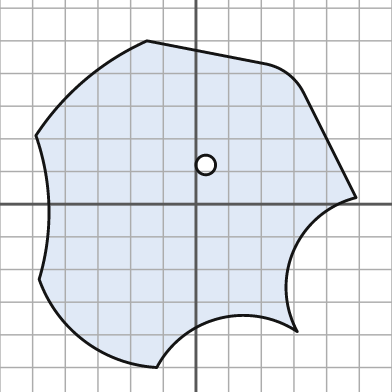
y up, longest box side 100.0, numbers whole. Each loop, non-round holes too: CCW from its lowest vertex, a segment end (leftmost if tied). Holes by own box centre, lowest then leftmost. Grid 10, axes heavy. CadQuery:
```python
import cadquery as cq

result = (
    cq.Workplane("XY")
    .moveTo(-12.0, -50.0)
    .threePointArc((7.0, -35.0), (31.0, -39.0))
    .threePointArc((30.0, -14.0), (49.0, 2.0))
    .lineTo(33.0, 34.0)
    .threePointArc((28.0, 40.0), (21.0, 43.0))
    .lineTo(-15.0, 50.0)
    .threePointArc((-34.0, 38.0), (-49.0, 21.0))
    .threePointArc((-45.0, -1.0), (-48.0, -23.0))
    .threePointArc((-34.0, -42.0), (-12.0, -50.0))
    .close()
    .moveTo(3.0, 12.0)
    .circle(3.0)
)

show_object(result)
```